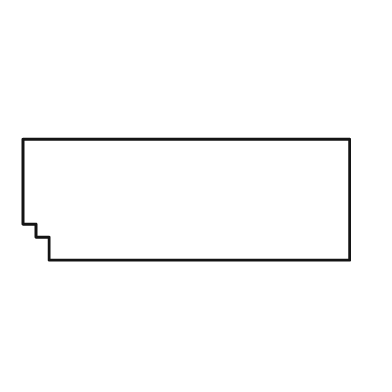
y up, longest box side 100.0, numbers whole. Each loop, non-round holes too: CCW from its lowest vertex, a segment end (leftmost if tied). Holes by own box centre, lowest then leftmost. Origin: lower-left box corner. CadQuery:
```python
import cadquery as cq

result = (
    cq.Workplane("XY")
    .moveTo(8.0, 0.0)
    .lineTo(100.0, 0.0)
    .lineTo(100.0, 37.0)
    .lineTo(0.0, 37.0)
    .lineTo(0.0, 11.0)
    .lineTo(4.0, 11.0)
    .lineTo(4.0, 7.0)
    .lineTo(8.0, 7.0)
    .close()
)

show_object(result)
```